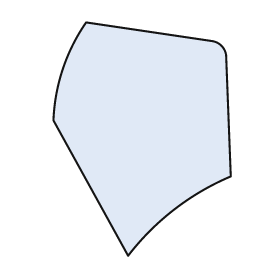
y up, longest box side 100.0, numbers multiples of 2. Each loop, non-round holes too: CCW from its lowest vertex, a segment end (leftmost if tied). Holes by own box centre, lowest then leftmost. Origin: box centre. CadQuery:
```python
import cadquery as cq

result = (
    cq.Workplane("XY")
    .moveTo(-6.0, -50.0)
    .threePointArc((14.0, -30.0), (38.0, -16.0))
    .lineTo(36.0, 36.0)
    .threePointArc((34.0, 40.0), (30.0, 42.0))
    .lineTo(-24.0, 50.0)
    .threePointArc((-34.0, 30.0), (-38.0, 8.0))
    .close()
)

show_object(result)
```